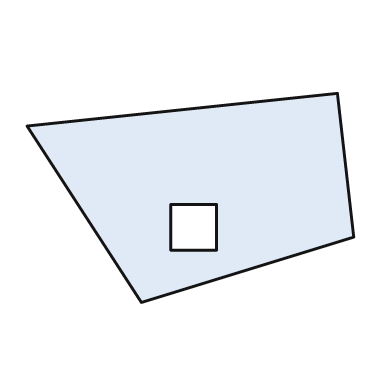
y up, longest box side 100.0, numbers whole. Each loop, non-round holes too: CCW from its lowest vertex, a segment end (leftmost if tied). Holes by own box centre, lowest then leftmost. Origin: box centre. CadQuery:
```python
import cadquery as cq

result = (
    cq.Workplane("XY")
    .moveTo(-15.0, -32.0)
    .lineTo(50.0, -12.0)
    .lineTo(45.0, 32.0)
    .lineTo(-50.0, 22.0)
    .close()
    .moveTo(-6.0, -16.0)
    .lineTo(8.0, -16.0)
    .lineTo(8.0, -2.0)
    .lineTo(-6.0, -2.0)
    .close()
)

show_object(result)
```